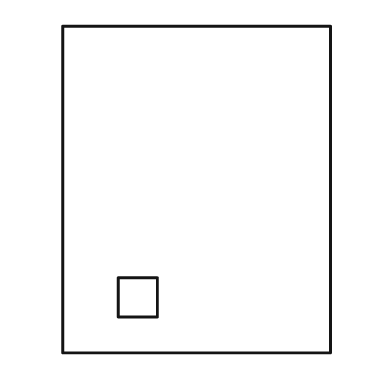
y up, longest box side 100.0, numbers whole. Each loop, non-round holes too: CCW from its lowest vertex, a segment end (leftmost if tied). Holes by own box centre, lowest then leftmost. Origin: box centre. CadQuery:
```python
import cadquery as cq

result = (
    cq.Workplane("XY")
    .moveTo(-41.0, -50.0)
    .lineTo(41.0, -50.0)
    .lineTo(41.0, 50.0)
    .lineTo(-41.0, 50.0)
    .close()
    .moveTo(-24.0, -39.0)
    .lineTo(-12.0, -39.0)
    .lineTo(-12.0, -27.0)
    .lineTo(-24.0, -27.0)
    .close()
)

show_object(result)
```